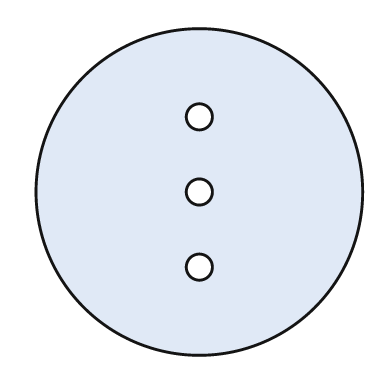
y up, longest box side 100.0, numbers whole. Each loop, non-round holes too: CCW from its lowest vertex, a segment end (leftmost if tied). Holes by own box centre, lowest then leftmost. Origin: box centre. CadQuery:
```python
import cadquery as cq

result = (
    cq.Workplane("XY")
    .moveTo(0.0, 0.0)
    .circle(50.0)
    .moveTo(0.0, -23.0)
    .circle(4.0)
    .moveTo(0.0, 0.0)
    .circle(4.0)
    .moveTo(0.0, 23.0)
    .circle(4.0)
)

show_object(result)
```